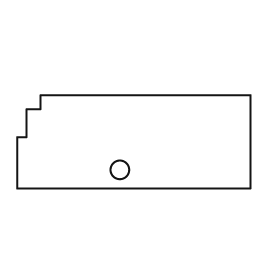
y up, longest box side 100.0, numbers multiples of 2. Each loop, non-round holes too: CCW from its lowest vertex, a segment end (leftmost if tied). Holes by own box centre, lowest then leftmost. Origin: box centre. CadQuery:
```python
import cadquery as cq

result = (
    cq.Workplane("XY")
    .moveTo(-50.0, -20.0)
    .lineTo(50.0, -20.0)
    .lineTo(50.0, 20.0)
    .lineTo(-40.0, 20.0)
    .lineTo(-40.0, 14.0)
    .lineTo(-46.0, 14.0)
    .lineTo(-46.0, 2.0)
    .lineTo(-50.0, 2.0)
    .close()
    .moveTo(-6.0, -12.0)
    .circle(4.0)
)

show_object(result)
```